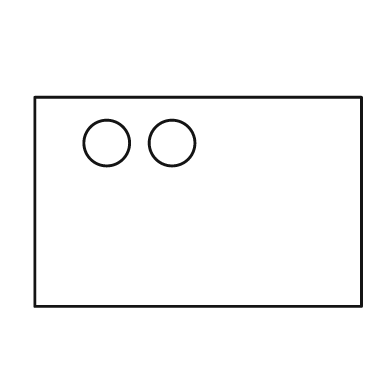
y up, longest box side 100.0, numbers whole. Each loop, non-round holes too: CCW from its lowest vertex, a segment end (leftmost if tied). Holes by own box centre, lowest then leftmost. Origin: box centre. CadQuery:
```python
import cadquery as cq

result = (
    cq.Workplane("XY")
    .moveTo(-50.0, -32.0)
    .lineTo(50.0, -32.0)
    .lineTo(50.0, 32.0)
    .lineTo(-50.0, 32.0)
    .close()
    .moveTo(-28.0, 18.0)
    .circle(7.0)
    .moveTo(-8.0, 18.0)
    .circle(7.0)
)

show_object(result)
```